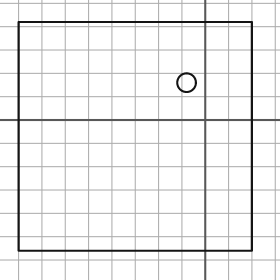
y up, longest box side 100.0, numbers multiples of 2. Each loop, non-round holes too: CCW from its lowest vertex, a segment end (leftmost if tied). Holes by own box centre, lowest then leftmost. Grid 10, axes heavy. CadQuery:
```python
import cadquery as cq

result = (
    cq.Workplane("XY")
    .moveTo(-80.0, -56.0)
    .lineTo(20.0, -56.0)
    .lineTo(20.0, 42.0)
    .lineTo(-80.0, 42.0)
    .close()
    .moveTo(-8.0, 16.0)
    .circle(4.0)
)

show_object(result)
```